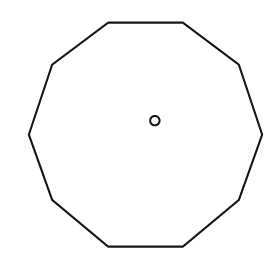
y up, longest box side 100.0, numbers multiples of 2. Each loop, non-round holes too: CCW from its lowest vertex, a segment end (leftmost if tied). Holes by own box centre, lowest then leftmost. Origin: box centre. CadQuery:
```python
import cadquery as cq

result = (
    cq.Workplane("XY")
    .moveTo(-16.0, -48.0)
    .lineTo(16.0, -48.0)
    .lineTo(40.0, -28.0)
    .lineTo(50.0, 0.0)
    .lineTo(40.0, 30.0)
    .lineTo(16.0, 48.0)
    .lineTo(-16.0, 48.0)
    .lineTo(-40.0, 30.0)
    .lineTo(-50.0, 0.0)
    .lineTo(-40.0, -28.0)
    .close()
    .moveTo(4.0, 6.0)
    .circle(2.0)
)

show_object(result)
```